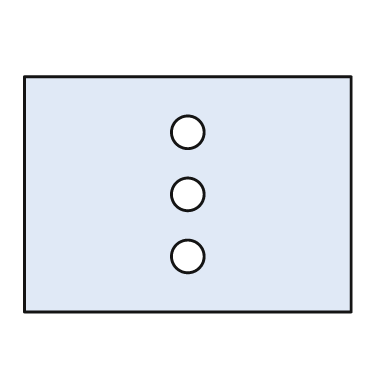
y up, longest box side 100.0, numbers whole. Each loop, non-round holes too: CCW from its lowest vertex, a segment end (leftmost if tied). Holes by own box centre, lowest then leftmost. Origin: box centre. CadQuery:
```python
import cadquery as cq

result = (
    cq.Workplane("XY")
    .moveTo(-50.0, -36.0)
    .lineTo(50.0, -36.0)
    .lineTo(50.0, 36.0)
    .lineTo(-50.0, 36.0)
    .close()
    .moveTo(0.0, -19.0)
    .circle(5.0)
    .moveTo(0.0, 0.0)
    .circle(5.0)
    .moveTo(0.0, 19.0)
    .circle(5.0)
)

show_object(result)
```